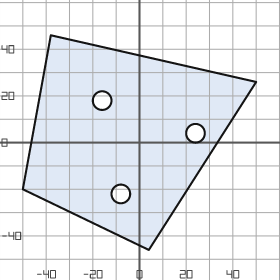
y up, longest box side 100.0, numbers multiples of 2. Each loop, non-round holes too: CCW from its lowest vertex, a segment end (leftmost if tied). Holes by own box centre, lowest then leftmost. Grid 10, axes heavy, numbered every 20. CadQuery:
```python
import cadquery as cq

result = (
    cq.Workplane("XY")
    .moveTo(4.0, -46.0)
    .lineTo(50.0, 26.0)
    .lineTo(-38.0, 46.0)
    .lineTo(-50.0, -20.0)
    .close()
    .moveTo(-8.0, -22.0)
    .circle(4.0)
    .moveTo(24.0, 4.0)
    .circle(4.0)
    .moveTo(-16.0, 18.0)
    .circle(4.0)
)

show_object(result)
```